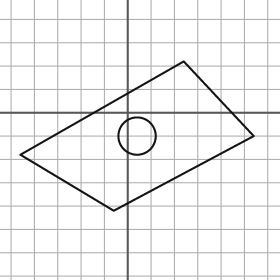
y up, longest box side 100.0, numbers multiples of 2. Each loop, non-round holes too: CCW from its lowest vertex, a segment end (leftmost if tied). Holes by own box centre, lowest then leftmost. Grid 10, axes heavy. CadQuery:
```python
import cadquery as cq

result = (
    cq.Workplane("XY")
    .moveTo(-6.0, -42.0)
    .lineTo(54.0, -10.0)
    .lineTo(24.0, 22.0)
    .lineTo(-46.0, -18.0)
    .close()
    .moveTo(4.0, -10.0)
    .circle(8.0)
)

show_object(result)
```